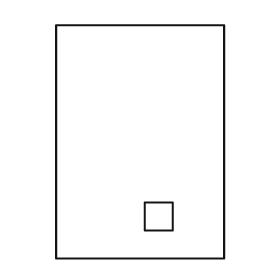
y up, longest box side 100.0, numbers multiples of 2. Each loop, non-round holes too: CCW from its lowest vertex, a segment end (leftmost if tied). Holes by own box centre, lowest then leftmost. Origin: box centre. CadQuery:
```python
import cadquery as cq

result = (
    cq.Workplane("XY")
    .moveTo(-36.0, -50.0)
    .lineTo(36.0, -50.0)
    .lineTo(36.0, 50.0)
    .lineTo(-36.0, 50.0)
    .close()
    .moveTo(2.0, -38.0)
    .lineTo(14.0, -38.0)
    .lineTo(14.0, -26.0)
    .lineTo(2.0, -26.0)
    .close()
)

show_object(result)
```